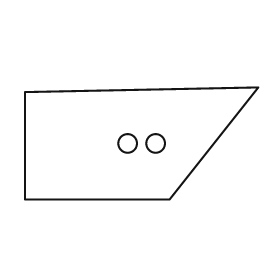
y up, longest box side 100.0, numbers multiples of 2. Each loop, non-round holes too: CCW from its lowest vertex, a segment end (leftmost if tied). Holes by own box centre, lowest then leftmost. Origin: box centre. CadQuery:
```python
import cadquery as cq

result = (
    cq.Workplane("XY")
    .moveTo(-50.0, -24.0)
    .lineTo(12.0, -24.0)
    .lineTo(50.0, 24.0)
    .lineTo(-50.0, 22.0)
    .close()
    .moveTo(-6.0, 0.0)
    .circle(4.0)
    .moveTo(6.0, 0.0)
    .circle(4.0)
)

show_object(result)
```